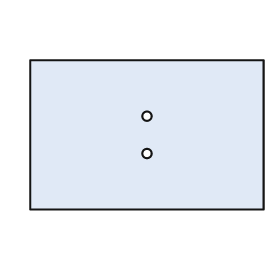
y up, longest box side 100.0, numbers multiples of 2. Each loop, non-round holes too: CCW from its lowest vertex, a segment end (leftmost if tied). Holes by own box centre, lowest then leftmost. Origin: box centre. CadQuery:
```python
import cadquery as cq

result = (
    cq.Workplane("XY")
    .moveTo(-50.0, -32.0)
    .lineTo(50.0, -32.0)
    .lineTo(50.0, 32.0)
    .lineTo(-50.0, 32.0)
    .close()
    .moveTo(0.0, -8.0)
    .circle(2.0)
    .moveTo(0.0, 8.0)
    .circle(2.0)
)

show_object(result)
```